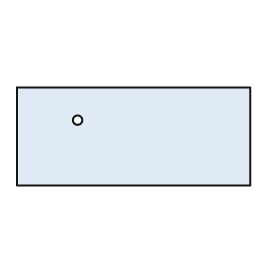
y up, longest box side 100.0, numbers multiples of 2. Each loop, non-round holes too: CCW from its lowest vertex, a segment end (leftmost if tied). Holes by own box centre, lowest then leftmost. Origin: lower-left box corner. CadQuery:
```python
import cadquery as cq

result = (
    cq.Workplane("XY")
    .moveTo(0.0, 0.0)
    .lineTo(100.0, 0.0)
    .lineTo(100.0, 42.0)
    .lineTo(0.0, 42.0)
    .close()
    .moveTo(26.0, 28.0)
    .circle(2.0)
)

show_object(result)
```